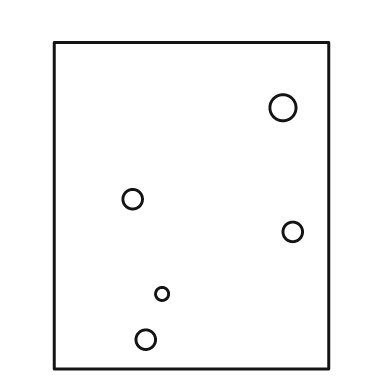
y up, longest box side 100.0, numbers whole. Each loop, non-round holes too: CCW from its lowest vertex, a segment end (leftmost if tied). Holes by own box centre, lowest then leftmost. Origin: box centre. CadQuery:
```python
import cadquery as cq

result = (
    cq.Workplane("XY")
    .moveTo(-42.0, -50.0)
    .lineTo(42.0, -50.0)
    .lineTo(42.0, 50.0)
    .lineTo(-42.0, 50.0)
    .close()
    .moveTo(-14.0, -41.0)
    .circle(3.0)
    .moveTo(-9.0, -27.0)
    .circle(2.0)
    .moveTo(31.0, -8.0)
    .circle(3.0)
    .moveTo(-18.0, 2.0)
    .circle(3.0)
    .moveTo(28.0, 30.0)
    .circle(4.0)
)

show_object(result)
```